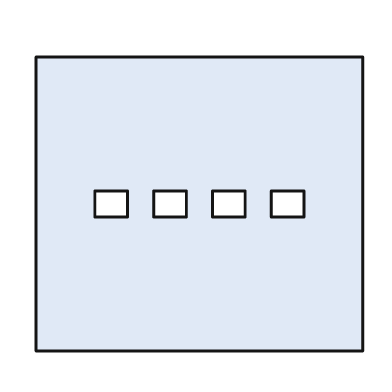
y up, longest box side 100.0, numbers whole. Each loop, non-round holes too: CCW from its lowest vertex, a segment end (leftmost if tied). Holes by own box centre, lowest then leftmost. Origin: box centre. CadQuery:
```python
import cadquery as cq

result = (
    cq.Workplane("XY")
    .moveTo(-50.0, -45.0)
    .lineTo(50.0, -45.0)
    .lineTo(50.0, 45.0)
    .lineTo(-50.0, 45.0)
    .close()
    .moveTo(-32.0, -4.0)
    .lineTo(-22.0, -4.0)
    .lineTo(-22.0, 4.0)
    .lineTo(-32.0, 4.0)
    .close()
    .moveTo(-14.0, -4.0)
    .lineTo(-4.0, -4.0)
    .lineTo(-4.0, 4.0)
    .lineTo(-14.0, 4.0)
    .close()
    .moveTo(4.0, -4.0)
    .lineTo(14.0, -4.0)
    .lineTo(14.0, 4.0)
    .lineTo(4.0, 4.0)
    .close()
    .moveTo(22.0, -4.0)
    .lineTo(32.0, -4.0)
    .lineTo(32.0, 4.0)
    .lineTo(22.0, 4.0)
    .close()
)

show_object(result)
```